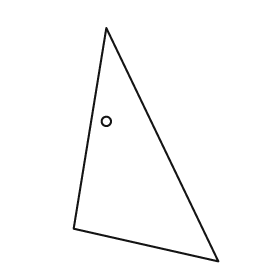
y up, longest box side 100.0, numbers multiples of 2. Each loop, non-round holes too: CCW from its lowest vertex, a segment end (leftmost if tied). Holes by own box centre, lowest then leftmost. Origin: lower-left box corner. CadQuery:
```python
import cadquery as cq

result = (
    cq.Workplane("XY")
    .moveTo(62.0, 0.0)
    .lineTo(14.0, 100.0)
    .lineTo(0.0, 14.0)
    .close()
    .moveTo(14.0, 60.0)
    .circle(2.0)
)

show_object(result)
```